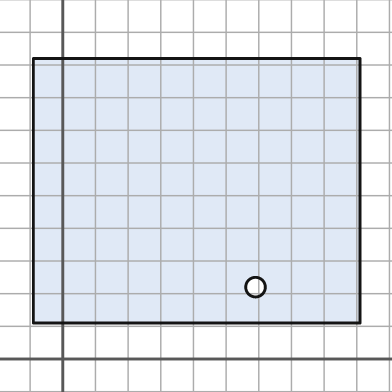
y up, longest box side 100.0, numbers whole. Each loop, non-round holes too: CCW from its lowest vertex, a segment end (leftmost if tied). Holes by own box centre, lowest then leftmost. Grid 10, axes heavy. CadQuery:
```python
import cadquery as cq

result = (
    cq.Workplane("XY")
    .moveTo(-9.0, 11.0)
    .lineTo(91.0, 11.0)
    .lineTo(91.0, 92.0)
    .lineTo(-9.0, 92.0)
    .close()
    .moveTo(59.0, 22.0)
    .circle(3.0)
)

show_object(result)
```